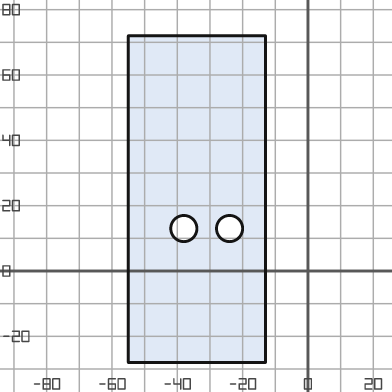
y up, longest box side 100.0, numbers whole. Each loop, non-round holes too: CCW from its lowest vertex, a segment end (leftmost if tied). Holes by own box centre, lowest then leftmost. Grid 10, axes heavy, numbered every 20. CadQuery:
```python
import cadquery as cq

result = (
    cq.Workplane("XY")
    .moveTo(-55.0, -28.0)
    .lineTo(-13.0, -28.0)
    .lineTo(-13.0, 72.0)
    .lineTo(-55.0, 72.0)
    .close()
    .moveTo(-38.0, 13.0)
    .circle(4.0)
    .moveTo(-24.0, 13.0)
    .circle(4.0)
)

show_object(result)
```